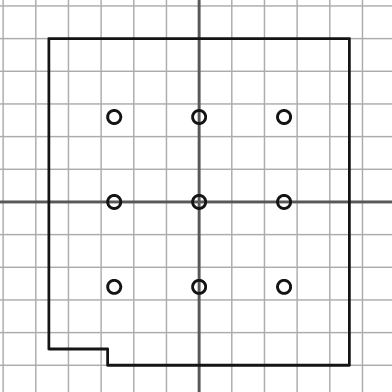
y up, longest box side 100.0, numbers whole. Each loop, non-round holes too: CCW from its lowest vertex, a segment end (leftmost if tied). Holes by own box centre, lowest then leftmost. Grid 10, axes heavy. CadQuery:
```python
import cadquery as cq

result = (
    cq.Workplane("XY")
    .moveTo(-28.0, -50.0)
    .lineTo(46.0, -50.0)
    .lineTo(46.0, 50.0)
    .lineTo(-46.0, 50.0)
    .lineTo(-46.0, -45.0)
    .lineTo(-28.0, -45.0)
    .close()
    .moveTo(-26.0, -26.0)
    .circle(2.0)
    .moveTo(0.0, -26.0)
    .circle(2.0)
    .moveTo(26.0, -26.0)
    .circle(2.0)
    .moveTo(-26.0, 0.0)
    .circle(2.0)
    .moveTo(0.0, 0.0)
    .circle(2.0)
    .moveTo(26.0, 0.0)
    .circle(2.0)
    .moveTo(-26.0, 26.0)
    .circle(2.0)
    .moveTo(0.0, 26.0)
    .circle(2.0)
    .moveTo(26.0, 26.0)
    .circle(2.0)
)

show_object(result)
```